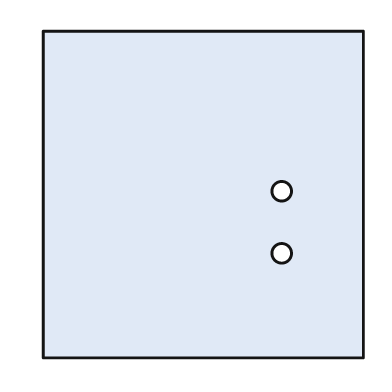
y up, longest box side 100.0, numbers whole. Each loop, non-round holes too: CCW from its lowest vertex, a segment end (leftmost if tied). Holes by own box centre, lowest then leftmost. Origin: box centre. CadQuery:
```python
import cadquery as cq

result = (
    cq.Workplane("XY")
    .moveTo(-49.0, -50.0)
    .lineTo(49.0, -50.0)
    .lineTo(49.0, 50.0)
    .lineTo(-49.0, 50.0)
    .close()
    .moveTo(24.0, -18.0)
    .circle(3.0)
    .moveTo(24.0, 1.0)
    .circle(3.0)
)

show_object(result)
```